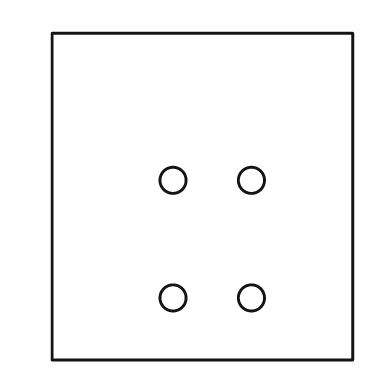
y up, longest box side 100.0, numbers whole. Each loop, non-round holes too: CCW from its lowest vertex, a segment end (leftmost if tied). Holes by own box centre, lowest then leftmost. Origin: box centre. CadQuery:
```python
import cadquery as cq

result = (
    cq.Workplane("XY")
    .moveTo(-46.0, -50.0)
    .lineTo(46.0, -50.0)
    .lineTo(46.0, 50.0)
    .lineTo(-46.0, 50.0)
    .close()
    .moveTo(-9.0, -31.0)
    .circle(4.0)
    .moveTo(15.0, -31.0)
    .circle(4.0)
    .moveTo(-9.0, 5.0)
    .circle(4.0)
    .moveTo(15.0, 5.0)
    .circle(4.0)
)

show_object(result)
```